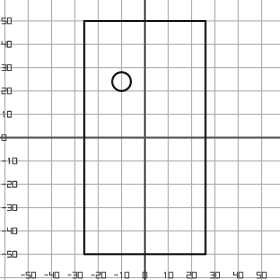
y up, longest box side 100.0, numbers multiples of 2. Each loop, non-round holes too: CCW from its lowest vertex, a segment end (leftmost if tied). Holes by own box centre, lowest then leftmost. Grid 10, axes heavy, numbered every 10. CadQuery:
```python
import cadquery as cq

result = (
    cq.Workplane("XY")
    .moveTo(-26.0, -50.0)
    .lineTo(26.0, -50.0)
    .lineTo(26.0, 50.0)
    .lineTo(-26.0, 50.0)
    .close()
    .moveTo(-10.0, 24.0)
    .circle(4.0)
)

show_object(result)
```